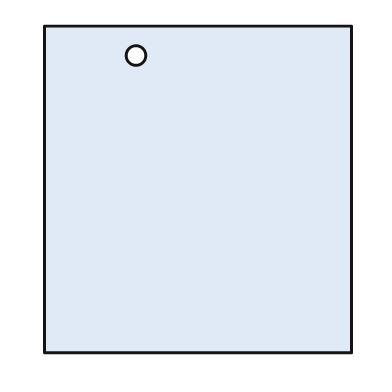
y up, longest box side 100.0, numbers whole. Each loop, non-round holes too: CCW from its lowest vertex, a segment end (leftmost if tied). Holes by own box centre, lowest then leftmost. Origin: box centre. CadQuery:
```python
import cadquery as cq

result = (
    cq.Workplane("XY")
    .moveTo(-47.0, -50.0)
    .lineTo(47.0, -50.0)
    .lineTo(47.0, 50.0)
    .lineTo(-47.0, 50.0)
    .close()
    .moveTo(-19.0, 41.0)
    .circle(3.0)
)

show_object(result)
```